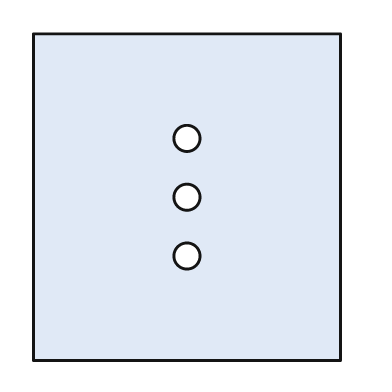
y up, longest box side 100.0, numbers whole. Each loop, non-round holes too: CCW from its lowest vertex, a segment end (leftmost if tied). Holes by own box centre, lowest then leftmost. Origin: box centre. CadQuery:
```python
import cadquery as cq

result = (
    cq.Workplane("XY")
    .moveTo(-47.0, -50.0)
    .lineTo(47.0, -50.0)
    .lineTo(47.0, 50.0)
    .lineTo(-47.0, 50.0)
    .close()
    .moveTo(0.0, -18.0)
    .circle(4.0)
    .moveTo(0.0, 0.0)
    .circle(4.0)
    .moveTo(0.0, 18.0)
    .circle(4.0)
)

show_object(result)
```